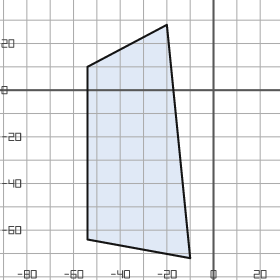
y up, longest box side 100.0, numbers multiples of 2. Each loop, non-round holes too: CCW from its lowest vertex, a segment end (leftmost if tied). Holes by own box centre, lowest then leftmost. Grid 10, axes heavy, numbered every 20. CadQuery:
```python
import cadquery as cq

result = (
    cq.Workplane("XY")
    .moveTo(-10.0, -72.0)
    .lineTo(-20.0, 28.0)
    .lineTo(-54.0, 10.0)
    .lineTo(-54.0, -64.0)
    .close()
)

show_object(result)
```